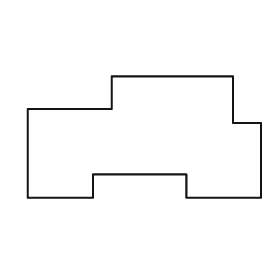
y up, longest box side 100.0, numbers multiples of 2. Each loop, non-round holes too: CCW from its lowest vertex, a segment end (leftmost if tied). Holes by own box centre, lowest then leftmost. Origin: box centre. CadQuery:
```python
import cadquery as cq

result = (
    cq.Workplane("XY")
    .moveTo(-50.0, -26.0)
    .lineTo(-22.0, -26.0)
    .lineTo(-22.0, -16.0)
    .lineTo(18.0, -16.0)
    .lineTo(18.0, -26.0)
    .lineTo(50.0, -26.0)
    .lineTo(50.0, 6.0)
    .lineTo(38.0, 6.0)
    .lineTo(38.0, 26.0)
    .lineTo(-14.0, 26.0)
    .lineTo(-14.0, 12.0)
    .lineTo(-50.0, 12.0)
    .close()
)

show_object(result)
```